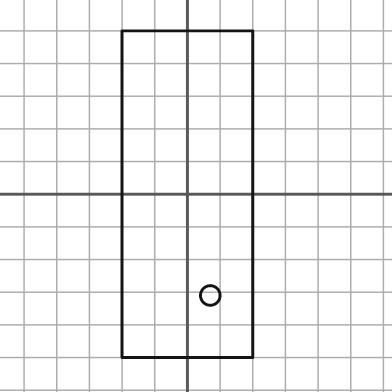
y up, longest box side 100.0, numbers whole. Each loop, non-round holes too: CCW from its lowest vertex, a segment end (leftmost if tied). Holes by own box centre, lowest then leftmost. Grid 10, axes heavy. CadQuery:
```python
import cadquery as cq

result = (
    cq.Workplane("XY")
    .moveTo(-20.0, -50.0)
    .lineTo(20.0, -50.0)
    .lineTo(20.0, 50.0)
    .lineTo(-20.0, 50.0)
    .close()
    .moveTo(7.0, -31.0)
    .circle(3.0)
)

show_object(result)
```